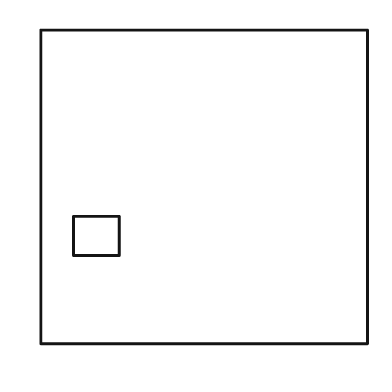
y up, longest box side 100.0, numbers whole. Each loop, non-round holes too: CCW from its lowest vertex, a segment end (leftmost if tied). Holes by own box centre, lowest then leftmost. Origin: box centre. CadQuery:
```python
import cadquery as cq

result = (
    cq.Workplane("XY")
    .moveTo(-50.0, -48.0)
    .lineTo(50.0, -48.0)
    .lineTo(50.0, 48.0)
    .lineTo(-50.0, 48.0)
    .close()
    .moveTo(-40.0, -21.0)
    .lineTo(-26.0, -21.0)
    .lineTo(-26.0, -9.0)
    .lineTo(-40.0, -9.0)
    .close()
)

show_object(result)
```